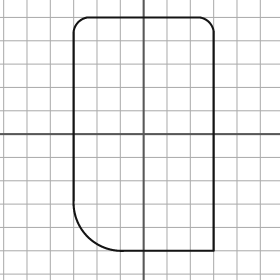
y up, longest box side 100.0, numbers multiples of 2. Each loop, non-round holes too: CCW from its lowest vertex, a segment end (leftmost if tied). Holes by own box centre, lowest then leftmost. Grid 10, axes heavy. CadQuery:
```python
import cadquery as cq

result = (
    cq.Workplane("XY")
    .moveTo(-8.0, -50.0)
    .lineTo(30.0, -50.0)
    .lineTo(30.0, 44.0)
    .threePointArc((28.0, 48.0), (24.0, 50.0))
    .lineTo(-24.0, 50.0)
    .threePointArc((-28.0, 48.0), (-30.0, 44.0))
    .lineTo(-30.0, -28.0)
    .threePointArc((-24.0, -44.0), (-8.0, -50.0))
    .close()
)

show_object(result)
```